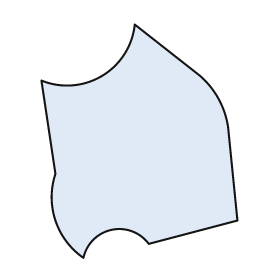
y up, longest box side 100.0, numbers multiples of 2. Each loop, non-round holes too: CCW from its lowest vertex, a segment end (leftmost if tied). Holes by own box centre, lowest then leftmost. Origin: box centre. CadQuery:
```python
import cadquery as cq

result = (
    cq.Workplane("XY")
    .moveTo(-24.0, -50.0)
    .threePointArc((-12.0, -38.0), (4.0, -44.0))
    .lineTo(42.0, -34.0)
    .lineTo(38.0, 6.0)
    .threePointArc((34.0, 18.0), (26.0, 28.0))
    .lineTo(-2.0, 50.0)
    .threePointArc((-16.0, 28.0), (-42.0, 26.0))
    .lineTo(-36.0, -14.0)
    .threePointArc((-36.0, -34.0), (-24.0, -50.0))
    .close()
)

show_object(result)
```